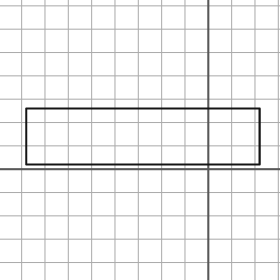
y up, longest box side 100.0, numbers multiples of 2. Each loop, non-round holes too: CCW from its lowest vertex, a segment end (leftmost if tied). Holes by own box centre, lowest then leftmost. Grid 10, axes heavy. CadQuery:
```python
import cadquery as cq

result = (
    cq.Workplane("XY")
    .moveTo(-78.0, 2.0)
    .lineTo(22.0, 2.0)
    .lineTo(22.0, 26.0)
    .lineTo(-78.0, 26.0)
    .close()
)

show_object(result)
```